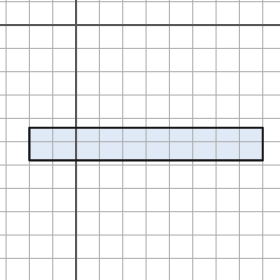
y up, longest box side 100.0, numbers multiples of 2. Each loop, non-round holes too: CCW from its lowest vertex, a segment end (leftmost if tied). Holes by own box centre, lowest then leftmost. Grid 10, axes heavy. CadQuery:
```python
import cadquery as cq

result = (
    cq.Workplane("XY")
    .moveTo(-20.0, -58.0)
    .lineTo(80.0, -58.0)
    .lineTo(80.0, -44.0)
    .lineTo(-20.0, -44.0)
    .close()
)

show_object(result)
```